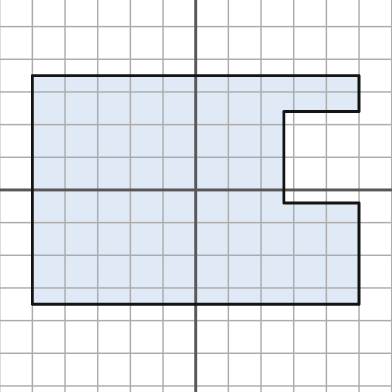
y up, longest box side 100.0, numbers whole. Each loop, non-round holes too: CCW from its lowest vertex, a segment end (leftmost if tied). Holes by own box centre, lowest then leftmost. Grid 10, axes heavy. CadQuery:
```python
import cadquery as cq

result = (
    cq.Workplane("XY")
    .moveTo(-50.0, -35.0)
    .lineTo(50.0, -35.0)
    .lineTo(50.0, -4.0)
    .lineTo(27.0, -4.0)
    .lineTo(27.0, 24.0)
    .lineTo(50.0, 24.0)
    .lineTo(50.0, 35.0)
    .lineTo(-50.0, 35.0)
    .close()
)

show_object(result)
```